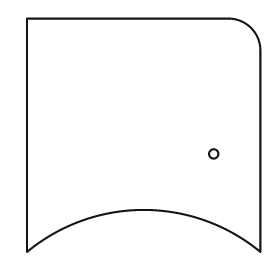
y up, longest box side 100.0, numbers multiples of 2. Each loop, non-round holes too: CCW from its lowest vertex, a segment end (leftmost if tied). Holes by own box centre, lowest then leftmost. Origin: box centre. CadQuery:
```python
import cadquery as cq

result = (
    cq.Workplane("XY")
    .moveTo(-50.0, -50.0)
    .threePointArc((0.0, -32.0), (50.0, -50.0))
    .lineTo(50.0, 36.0)
    .threePointArc((46.0, 46.0), (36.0, 50.0))
    .lineTo(-50.0, 50.0)
    .close()
    .moveTo(30.0, -8.0)
    .circle(2.0)
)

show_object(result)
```